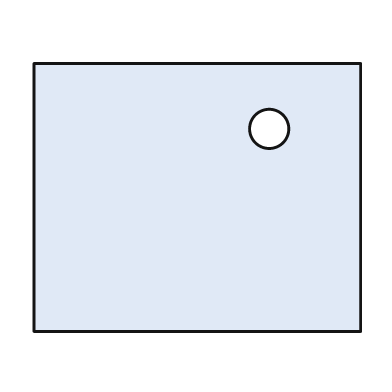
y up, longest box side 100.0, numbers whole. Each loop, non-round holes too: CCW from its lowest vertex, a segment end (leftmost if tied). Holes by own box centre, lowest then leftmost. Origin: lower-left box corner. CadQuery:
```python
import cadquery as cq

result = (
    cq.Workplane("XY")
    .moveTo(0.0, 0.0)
    .lineTo(100.0, 0.0)
    .lineTo(100.0, 82.0)
    .lineTo(0.0, 82.0)
    .close()
    .moveTo(72.0, 62.0)
    .circle(6.0)
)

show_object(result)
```